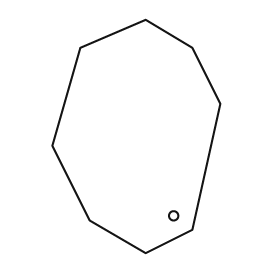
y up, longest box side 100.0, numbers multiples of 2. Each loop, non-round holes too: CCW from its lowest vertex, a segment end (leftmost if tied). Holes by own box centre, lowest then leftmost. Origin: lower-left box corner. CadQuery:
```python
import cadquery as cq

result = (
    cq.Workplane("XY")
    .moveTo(40.0, 0.0)
    .lineTo(60.0, 10.0)
    .lineTo(72.0, 64.0)
    .lineTo(60.0, 88.0)
    .lineTo(40.0, 100.0)
    .lineTo(12.0, 88.0)
    .lineTo(0.0, 46.0)
    .lineTo(16.0, 14.0)
    .close()
    .moveTo(52.0, 16.0)
    .circle(2.0)
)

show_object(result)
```